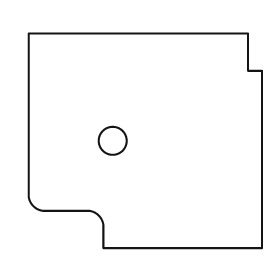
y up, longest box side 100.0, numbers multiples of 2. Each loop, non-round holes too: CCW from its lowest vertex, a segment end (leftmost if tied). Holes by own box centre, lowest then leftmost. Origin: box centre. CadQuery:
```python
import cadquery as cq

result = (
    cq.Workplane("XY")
    .moveTo(-18.0, -46.0)
    .lineTo(50.0, -46.0)
    .lineTo(50.0, 30.0)
    .lineTo(44.0, 30.0)
    .lineTo(44.0, 46.0)
    .lineTo(-50.0, 46.0)
    .lineTo(-50.0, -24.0)
    .threePointArc((-48.0, -28.0), (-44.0, -30.0))
    .lineTo(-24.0, -30.0)
    .threePointArc((-20.0, -32.0), (-18.0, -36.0))
    .close()
    .moveTo(-14.0, 0.0)
    .circle(6.0)
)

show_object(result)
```